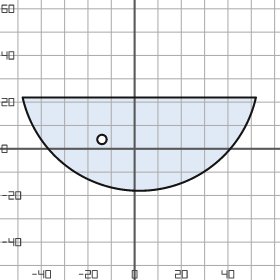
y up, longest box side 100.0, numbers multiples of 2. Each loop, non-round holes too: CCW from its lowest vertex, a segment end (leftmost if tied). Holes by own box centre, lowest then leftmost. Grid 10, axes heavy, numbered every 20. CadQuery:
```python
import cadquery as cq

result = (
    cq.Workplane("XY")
    .moveTo(-48.0, 22.0)
    .threePointArc((2.0, -18.0), (52.0, 22.0))
    .close()
    .moveTo(-14.0, 4.0)
    .circle(2.0)
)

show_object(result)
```